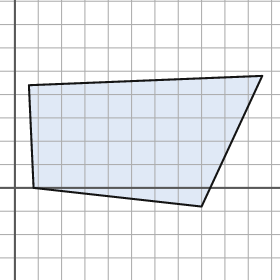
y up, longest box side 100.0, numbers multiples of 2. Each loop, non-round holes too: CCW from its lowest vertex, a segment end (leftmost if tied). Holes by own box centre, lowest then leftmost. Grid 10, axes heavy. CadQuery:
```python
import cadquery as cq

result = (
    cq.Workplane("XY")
    .moveTo(80.0, -8.0)
    .lineTo(106.0, 48.0)
    .lineTo(6.0, 44.0)
    .lineTo(8.0, 0.0)
    .close()
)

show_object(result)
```